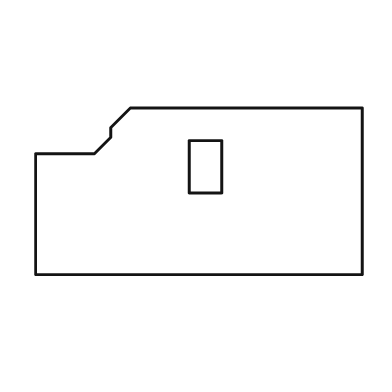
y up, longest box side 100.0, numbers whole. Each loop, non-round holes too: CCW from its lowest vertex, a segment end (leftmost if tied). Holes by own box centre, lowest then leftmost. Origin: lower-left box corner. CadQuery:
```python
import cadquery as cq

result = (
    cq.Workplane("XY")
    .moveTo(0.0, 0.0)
    .lineTo(100.0, 0.0)
    .lineTo(100.0, 51.0)
    .lineTo(29.0, 51.0)
    .lineTo(23.0, 45.0)
    .lineTo(23.0, 42.0)
    .lineTo(18.0, 37.0)
    .lineTo(0.0, 37.0)
    .close()
    .moveTo(47.0, 25.0)
    .lineTo(57.0, 25.0)
    .lineTo(57.0, 41.0)
    .lineTo(47.0, 41.0)
    .close()
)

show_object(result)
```